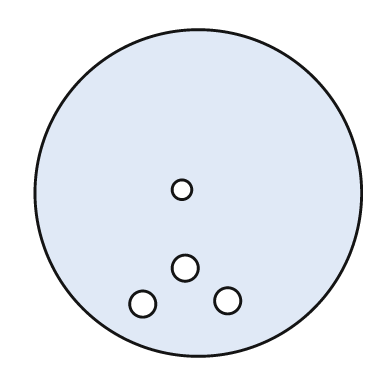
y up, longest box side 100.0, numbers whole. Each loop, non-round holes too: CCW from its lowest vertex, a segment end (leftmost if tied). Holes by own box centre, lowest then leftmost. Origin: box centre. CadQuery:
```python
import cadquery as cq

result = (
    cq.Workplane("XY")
    .moveTo(0.0, 0.0)
    .circle(50.0)
    .moveTo(-17.0, -34.0)
    .circle(4.0)
    .moveTo(9.0, -33.0)
    .circle(4.0)
    .moveTo(-4.0, -23.0)
    .circle(4.0)
    .moveTo(-5.0, 1.0)
    .circle(3.0)
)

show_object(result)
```